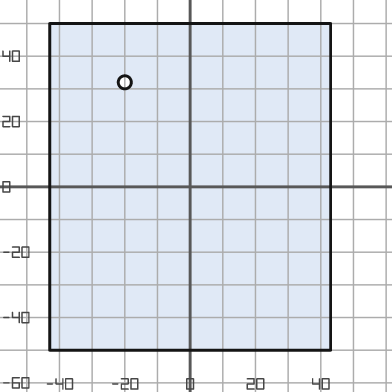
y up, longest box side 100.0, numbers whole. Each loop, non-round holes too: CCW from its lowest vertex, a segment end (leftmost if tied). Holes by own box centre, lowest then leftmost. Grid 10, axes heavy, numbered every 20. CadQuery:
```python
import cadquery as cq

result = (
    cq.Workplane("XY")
    .moveTo(-43.0, -50.0)
    .lineTo(43.0, -50.0)
    .lineTo(43.0, 50.0)
    .lineTo(-43.0, 50.0)
    .close()
    .moveTo(-20.0, 32.0)
    .circle(2.0)
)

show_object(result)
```